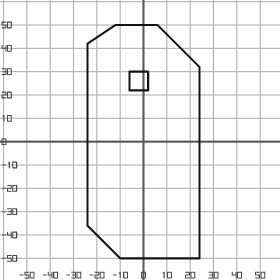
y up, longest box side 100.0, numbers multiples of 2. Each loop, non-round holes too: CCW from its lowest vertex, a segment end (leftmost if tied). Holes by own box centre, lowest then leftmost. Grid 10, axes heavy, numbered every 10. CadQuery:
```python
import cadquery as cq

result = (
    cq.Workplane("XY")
    .moveTo(-10.0, -50.0)
    .lineTo(24.0, -50.0)
    .lineTo(24.0, 32.0)
    .lineTo(6.0, 50.0)
    .lineTo(-12.0, 50.0)
    .lineTo(-24.0, 42.0)
    .lineTo(-24.0, -36.0)
    .close()
    .moveTo(-6.0, 22.0)
    .lineTo(2.0, 22.0)
    .lineTo(2.0, 30.0)
    .lineTo(-6.0, 30.0)
    .close()
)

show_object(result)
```